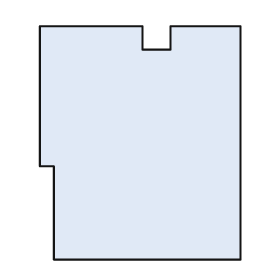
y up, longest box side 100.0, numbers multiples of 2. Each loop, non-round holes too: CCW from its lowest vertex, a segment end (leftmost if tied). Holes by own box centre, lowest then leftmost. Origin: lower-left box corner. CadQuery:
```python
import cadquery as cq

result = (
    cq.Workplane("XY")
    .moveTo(6.0, 0.0)
    .lineTo(86.0, 0.0)
    .lineTo(86.0, 100.0)
    .lineTo(56.0, 100.0)
    .lineTo(56.0, 90.0)
    .lineTo(44.0, 90.0)
    .lineTo(44.0, 100.0)
    .lineTo(0.0, 100.0)
    .lineTo(0.0, 40.0)
    .lineTo(6.0, 40.0)
    .close()
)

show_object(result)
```